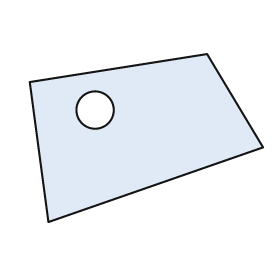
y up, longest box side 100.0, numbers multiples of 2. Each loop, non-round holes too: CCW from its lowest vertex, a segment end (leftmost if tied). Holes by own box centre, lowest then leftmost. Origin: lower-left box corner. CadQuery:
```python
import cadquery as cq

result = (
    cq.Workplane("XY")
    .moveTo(8.0, 0.0)
    .lineTo(100.0, 32.0)
    .lineTo(76.0, 72.0)
    .lineTo(0.0, 60.0)
    .close()
    .moveTo(28.0, 48.0)
    .circle(8.0)
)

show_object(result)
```